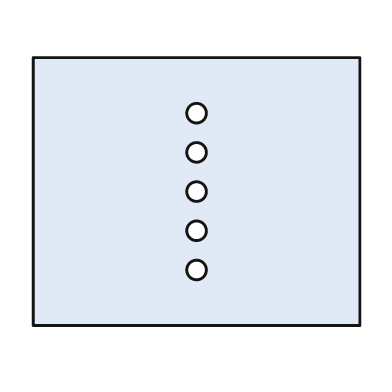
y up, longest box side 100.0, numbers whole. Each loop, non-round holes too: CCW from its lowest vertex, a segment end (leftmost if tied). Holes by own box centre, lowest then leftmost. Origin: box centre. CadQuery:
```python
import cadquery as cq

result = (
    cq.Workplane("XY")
    .moveTo(-50.0, -41.0)
    .lineTo(50.0, -41.0)
    .lineTo(50.0, 41.0)
    .lineTo(-50.0, 41.0)
    .close()
    .moveTo(0.0, -24.0)
    .circle(3.0)
    .moveTo(0.0, -12.0)
    .circle(3.0)
    .moveTo(0.0, 0.0)
    .circle(3.0)
    .moveTo(0.0, 12.0)
    .circle(3.0)
    .moveTo(0.0, 24.0)
    .circle(3.0)
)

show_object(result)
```